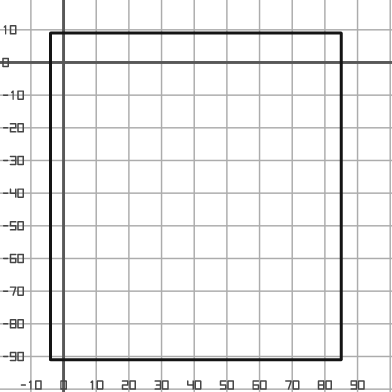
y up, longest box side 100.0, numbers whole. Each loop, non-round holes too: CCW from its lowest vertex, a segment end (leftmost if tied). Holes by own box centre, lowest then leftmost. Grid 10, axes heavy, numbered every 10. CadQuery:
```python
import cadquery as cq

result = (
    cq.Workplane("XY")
    .moveTo(-4.0, -91.0)
    .lineTo(85.0, -91.0)
    .lineTo(85.0, 9.0)
    .lineTo(-4.0, 9.0)
    .close()
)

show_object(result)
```